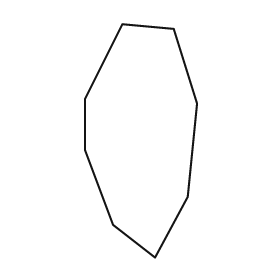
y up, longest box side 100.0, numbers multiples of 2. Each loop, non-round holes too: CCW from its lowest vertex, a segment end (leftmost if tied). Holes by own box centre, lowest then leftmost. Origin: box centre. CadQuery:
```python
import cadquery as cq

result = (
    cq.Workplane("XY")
    .moveTo(6.0, -50.0)
    .lineTo(20.0, -24.0)
    .lineTo(24.0, 16.0)
    .lineTo(14.0, 48.0)
    .lineTo(-8.0, 50.0)
    .lineTo(-24.0, 18.0)
    .lineTo(-24.0, -4.0)
    .lineTo(-12.0, -36.0)
    .close()
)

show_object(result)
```